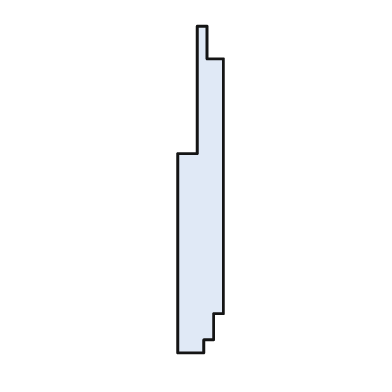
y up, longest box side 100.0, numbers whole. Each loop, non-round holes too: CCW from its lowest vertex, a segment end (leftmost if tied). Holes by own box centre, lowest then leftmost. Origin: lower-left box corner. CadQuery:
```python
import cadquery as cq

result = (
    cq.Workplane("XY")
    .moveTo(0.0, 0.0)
    .lineTo(8.0, 0.0)
    .lineTo(8.0, 4.0)
    .lineTo(11.0, 4.0)
    .lineTo(11.0, 12.0)
    .lineTo(14.0, 12.0)
    .lineTo(14.0, 90.0)
    .lineTo(9.0, 90.0)
    .lineTo(9.0, 100.0)
    .lineTo(6.0, 100.0)
    .lineTo(6.0, 61.0)
    .lineTo(0.0, 61.0)
    .close()
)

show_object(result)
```